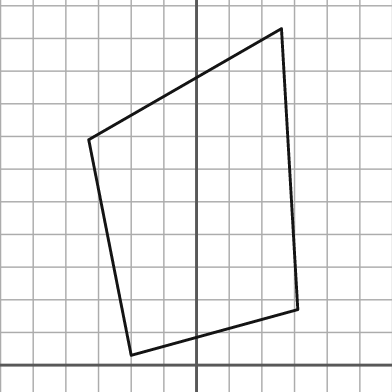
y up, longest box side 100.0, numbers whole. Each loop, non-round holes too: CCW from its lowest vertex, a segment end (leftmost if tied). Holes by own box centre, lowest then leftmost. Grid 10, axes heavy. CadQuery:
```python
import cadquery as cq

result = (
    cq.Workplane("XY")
    .moveTo(-20.0, 3.0)
    .lineTo(31.0, 17.0)
    .lineTo(26.0, 103.0)
    .lineTo(-33.0, 69.0)
    .close()
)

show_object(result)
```